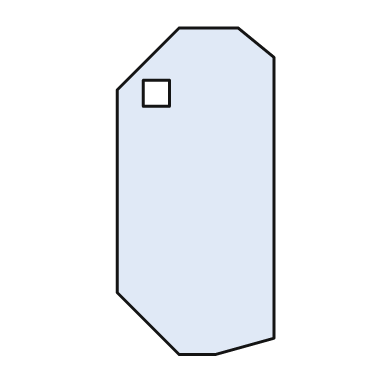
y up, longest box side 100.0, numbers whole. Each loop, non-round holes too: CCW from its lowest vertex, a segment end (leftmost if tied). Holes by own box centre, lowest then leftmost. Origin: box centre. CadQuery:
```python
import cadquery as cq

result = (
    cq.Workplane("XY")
    .moveTo(-5.0, -50.0)
    .lineTo(6.0, -50.0)
    .lineTo(24.0, -45.0)
    .lineTo(24.0, 41.0)
    .lineTo(13.0, 50.0)
    .lineTo(-5.0, 50.0)
    .lineTo(-24.0, 31.0)
    .lineTo(-24.0, -31.0)
    .close()
    .moveTo(-16.0, 26.0)
    .lineTo(-8.0, 26.0)
    .lineTo(-8.0, 34.0)
    .lineTo(-16.0, 34.0)
    .close()
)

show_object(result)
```